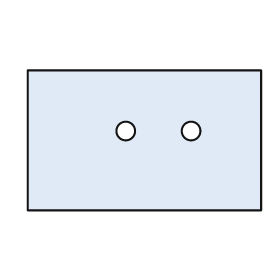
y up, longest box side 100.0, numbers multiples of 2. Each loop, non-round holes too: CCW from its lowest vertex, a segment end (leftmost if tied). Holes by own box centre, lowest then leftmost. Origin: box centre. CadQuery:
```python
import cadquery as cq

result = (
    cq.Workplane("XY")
    .moveTo(-50.0, -30.0)
    .lineTo(50.0, -30.0)
    .lineTo(50.0, 30.0)
    .lineTo(-50.0, 30.0)
    .close()
    .moveTo(-8.0, 4.0)
    .circle(4.0)
    .moveTo(20.0, 4.0)
    .circle(4.0)
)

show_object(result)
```